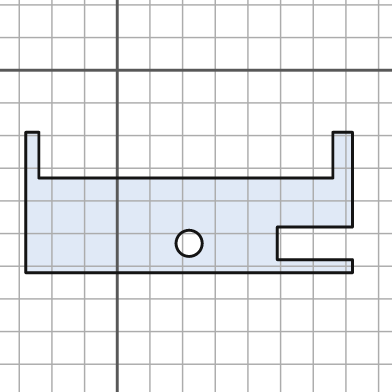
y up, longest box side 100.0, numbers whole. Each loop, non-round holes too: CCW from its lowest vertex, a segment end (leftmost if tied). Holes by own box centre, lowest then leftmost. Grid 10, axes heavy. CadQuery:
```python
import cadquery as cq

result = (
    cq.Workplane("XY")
    .moveTo(-28.0, -62.0)
    .lineTo(72.0, -62.0)
    .lineTo(72.0, -58.0)
    .lineTo(49.0, -58.0)
    .lineTo(49.0, -48.0)
    .lineTo(72.0, -48.0)
    .lineTo(72.0, -19.0)
    .lineTo(66.0, -19.0)
    .lineTo(66.0, -33.0)
    .lineTo(-24.0, -33.0)
    .lineTo(-24.0, -19.0)
    .lineTo(-28.0, -19.0)
    .close()
    .moveTo(22.0, -53.0)
    .circle(4.0)
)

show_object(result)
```